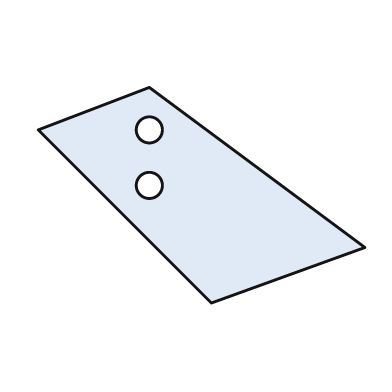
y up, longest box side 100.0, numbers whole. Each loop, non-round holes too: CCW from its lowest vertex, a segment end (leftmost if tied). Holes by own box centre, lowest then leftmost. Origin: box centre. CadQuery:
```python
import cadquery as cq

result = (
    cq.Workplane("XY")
    .moveTo(3.0, -33.0)
    .lineTo(50.0, -16.0)
    .lineTo(-16.0, 33.0)
    .lineTo(-50.0, 20.0)
    .close()
    .moveTo(-16.0, 3.0)
    .circle(4.0)
    .moveTo(-16.0, 20.0)
    .circle(4.0)
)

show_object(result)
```